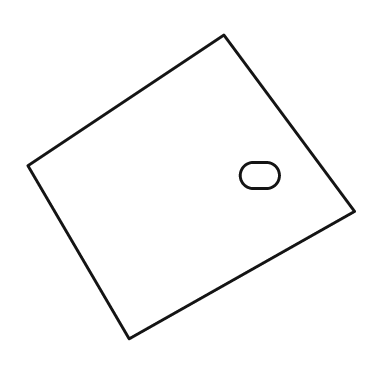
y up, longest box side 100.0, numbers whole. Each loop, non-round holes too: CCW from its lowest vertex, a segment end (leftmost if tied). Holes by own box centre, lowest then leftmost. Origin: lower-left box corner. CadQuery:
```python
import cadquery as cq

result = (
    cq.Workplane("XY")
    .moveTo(31.0, 0.0)
    .lineTo(100.0, 39.0)
    .lineTo(60.0, 93.0)
    .lineTo(0.0, 53.0)
    .close()
    .moveTo(69.0, 46.0)
    .lineTo(73.0, 46.0)
    .threePointArc((77.0, 50.0), (73.0, 54.0))
    .lineTo(69.0, 54.0)
    .threePointArc((65.0, 50.0), (69.0, 46.0))
    .close()
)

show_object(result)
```